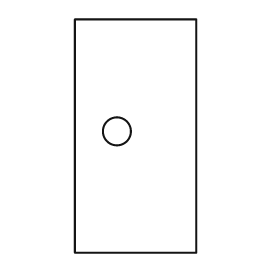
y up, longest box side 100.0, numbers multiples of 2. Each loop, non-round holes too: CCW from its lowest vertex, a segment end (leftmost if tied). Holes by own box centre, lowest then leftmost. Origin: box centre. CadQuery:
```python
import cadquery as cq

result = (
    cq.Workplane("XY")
    .moveTo(-26.0, -50.0)
    .lineTo(26.0, -50.0)
    .lineTo(26.0, 50.0)
    .lineTo(-26.0, 50.0)
    .close()
    .moveTo(-8.0, 2.0)
    .circle(6.0)
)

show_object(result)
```